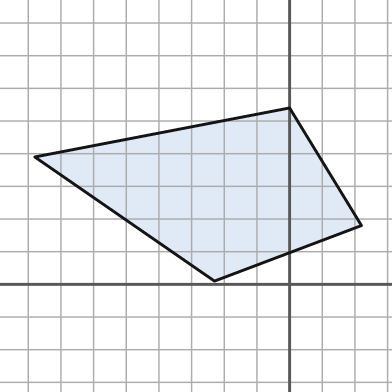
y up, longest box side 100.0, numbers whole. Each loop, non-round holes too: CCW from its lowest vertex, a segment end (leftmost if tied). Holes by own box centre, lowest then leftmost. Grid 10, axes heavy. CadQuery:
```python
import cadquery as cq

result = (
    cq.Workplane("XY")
    .moveTo(-23.0, 1.0)
    .lineTo(22.0, 18.0)
    .lineTo(0.0, 54.0)
    .lineTo(-78.0, 39.0)
    .close()
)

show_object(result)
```